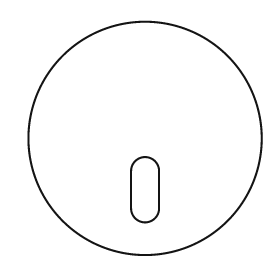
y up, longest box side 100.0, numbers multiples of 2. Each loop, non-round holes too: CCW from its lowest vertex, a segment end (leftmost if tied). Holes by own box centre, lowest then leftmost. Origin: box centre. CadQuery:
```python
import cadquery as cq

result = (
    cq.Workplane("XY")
    .moveTo(0.0, 0.0)
    .circle(50.0)
    .moveTo(-6.0, -30.0)
    .threePointArc((0.0, -36.0), (6.0, -30.0))
    .lineTo(6.0, -14.0)
    .threePointArc((0.0, -8.0), (-6.0, -14.0))
    .close()
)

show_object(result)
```